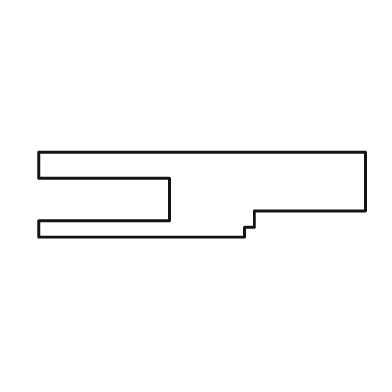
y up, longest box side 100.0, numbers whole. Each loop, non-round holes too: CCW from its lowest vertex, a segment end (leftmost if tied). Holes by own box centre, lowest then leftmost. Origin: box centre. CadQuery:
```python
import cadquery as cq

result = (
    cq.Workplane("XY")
    .moveTo(-50.0, -13.0)
    .lineTo(13.0, -13.0)
    .lineTo(13.0, -10.0)
    .lineTo(16.0, -10.0)
    .lineTo(16.0, -5.0)
    .lineTo(50.0, -5.0)
    .lineTo(50.0, 13.0)
    .lineTo(-50.0, 13.0)
    .lineTo(-50.0, 5.0)
    .lineTo(-10.0, 5.0)
    .lineTo(-10.0, -8.0)
    .lineTo(-50.0, -8.0)
    .close()
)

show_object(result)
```